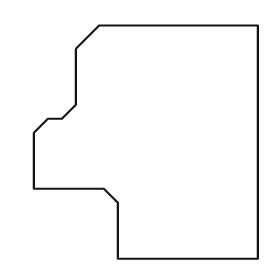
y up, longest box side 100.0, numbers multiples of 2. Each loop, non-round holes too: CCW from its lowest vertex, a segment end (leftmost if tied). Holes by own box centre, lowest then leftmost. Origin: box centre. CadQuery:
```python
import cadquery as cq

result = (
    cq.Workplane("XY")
    .moveTo(-12.0, -50.0)
    .lineTo(48.0, -50.0)
    .lineTo(48.0, 50.0)
    .lineTo(-20.0, 50.0)
    .lineTo(-30.0, 40.0)
    .lineTo(-30.0, 16.0)
    .lineTo(-36.0, 10.0)
    .lineTo(-42.0, 10.0)
    .lineTo(-48.0, 4.0)
    .lineTo(-48.0, -20.0)
    .lineTo(-18.0, -20.0)
    .lineTo(-12.0, -26.0)
    .close()
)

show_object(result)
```